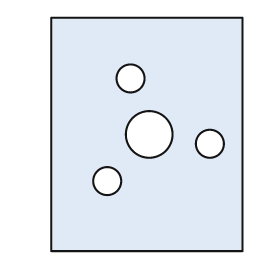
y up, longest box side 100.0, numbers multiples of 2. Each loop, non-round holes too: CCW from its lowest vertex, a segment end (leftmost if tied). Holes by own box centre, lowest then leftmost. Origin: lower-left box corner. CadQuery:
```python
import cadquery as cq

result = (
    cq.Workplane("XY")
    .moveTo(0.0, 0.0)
    .lineTo(82.0, 0.0)
    .lineTo(82.0, 100.0)
    .lineTo(0.0, 100.0)
    .close()
    .moveTo(24.0, 30.0)
    .circle(6.0)
    .moveTo(68.0, 46.0)
    .circle(6.0)
    .moveTo(42.0, 50.0)
    .circle(10.0)
    .moveTo(34.0, 74.0)
    .circle(6.0)
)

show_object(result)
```